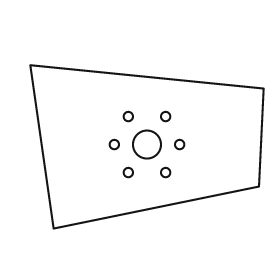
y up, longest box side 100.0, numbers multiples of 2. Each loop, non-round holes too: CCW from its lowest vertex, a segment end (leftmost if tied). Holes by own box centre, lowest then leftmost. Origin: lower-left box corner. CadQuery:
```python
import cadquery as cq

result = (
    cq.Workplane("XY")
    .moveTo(10.0, 0.0)
    .lineTo(98.0, 18.0)
    .lineTo(100.0, 60.0)
    .lineTo(0.0, 70.0)
    .close()
    .moveTo(42.0, 24.0)
    .circle(2.0)
    .moveTo(58.0, 24.0)
    .circle(2.0)
    .moveTo(36.0, 36.0)
    .circle(2.0)
    .moveTo(50.0, 36.0)
    .circle(6.0)
    .moveTo(64.0, 36.0)
    .circle(2.0)
    .moveTo(42.0, 48.0)
    .circle(2.0)
    .moveTo(58.0, 48.0)
    .circle(2.0)
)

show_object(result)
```